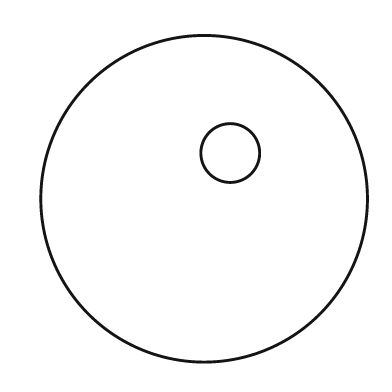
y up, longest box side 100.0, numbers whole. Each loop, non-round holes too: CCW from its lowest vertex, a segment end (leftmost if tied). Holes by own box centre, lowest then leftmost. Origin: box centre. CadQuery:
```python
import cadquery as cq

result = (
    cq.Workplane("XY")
    .moveTo(0.0, 0.0)
    .circle(50.0)
    .moveTo(8.0, 14.0)
    .circle(9.0)
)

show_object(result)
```